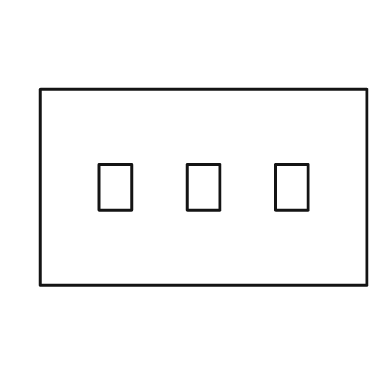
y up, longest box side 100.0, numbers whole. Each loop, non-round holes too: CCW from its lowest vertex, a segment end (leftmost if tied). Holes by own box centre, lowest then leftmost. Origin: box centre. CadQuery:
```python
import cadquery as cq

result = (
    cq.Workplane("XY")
    .moveTo(-50.0, -30.0)
    .lineTo(50.0, -30.0)
    .lineTo(50.0, 30.0)
    .lineTo(-50.0, 30.0)
    .close()
    .moveTo(-32.0, -7.0)
    .lineTo(-22.0, -7.0)
    .lineTo(-22.0, 7.0)
    .lineTo(-32.0, 7.0)
    .close()
    .moveTo(-5.0, -7.0)
    .lineTo(5.0, -7.0)
    .lineTo(5.0, 7.0)
    .lineTo(-5.0, 7.0)
    .close()
    .moveTo(22.0, -7.0)
    .lineTo(32.0, -7.0)
    .lineTo(32.0, 7.0)
    .lineTo(22.0, 7.0)
    .close()
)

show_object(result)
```